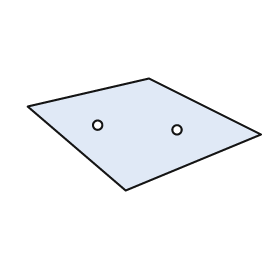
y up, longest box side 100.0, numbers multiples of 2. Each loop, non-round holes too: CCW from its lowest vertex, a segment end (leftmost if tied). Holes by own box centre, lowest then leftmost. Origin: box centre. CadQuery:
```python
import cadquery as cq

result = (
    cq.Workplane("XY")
    .moveTo(-8.0, -24.0)
    .lineTo(50.0, 0.0)
    .lineTo(2.0, 24.0)
    .lineTo(-50.0, 12.0)
    .close()
    .moveTo(14.0, 2.0)
    .circle(2.0)
    .moveTo(-20.0, 4.0)
    .circle(2.0)
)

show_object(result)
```